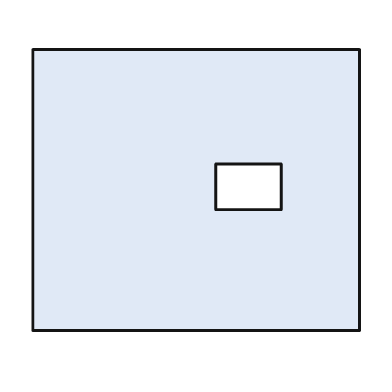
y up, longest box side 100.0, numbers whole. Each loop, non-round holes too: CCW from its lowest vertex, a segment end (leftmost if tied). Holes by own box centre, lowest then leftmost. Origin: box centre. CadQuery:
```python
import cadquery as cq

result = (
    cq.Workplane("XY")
    .moveTo(-50.0, -43.0)
    .lineTo(50.0, -43.0)
    .lineTo(50.0, 43.0)
    .lineTo(-50.0, 43.0)
    .close()
    .moveTo(6.0, -6.0)
    .lineTo(26.0, -6.0)
    .lineTo(26.0, 8.0)
    .lineTo(6.0, 8.0)
    .close()
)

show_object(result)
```